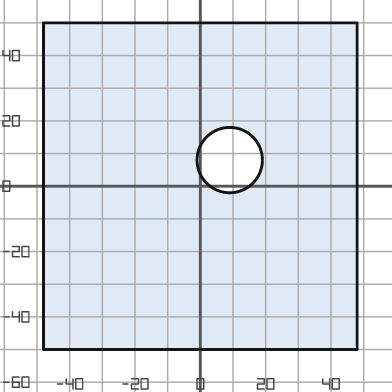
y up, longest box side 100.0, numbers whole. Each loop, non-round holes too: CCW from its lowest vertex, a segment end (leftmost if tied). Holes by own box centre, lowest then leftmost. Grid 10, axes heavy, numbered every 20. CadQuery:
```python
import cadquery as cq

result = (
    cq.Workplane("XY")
    .moveTo(-48.0, -50.0)
    .lineTo(48.0, -50.0)
    .lineTo(48.0, 50.0)
    .lineTo(-48.0, 50.0)
    .close()
    .moveTo(9.0, 8.0)
    .circle(10.0)
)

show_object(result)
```